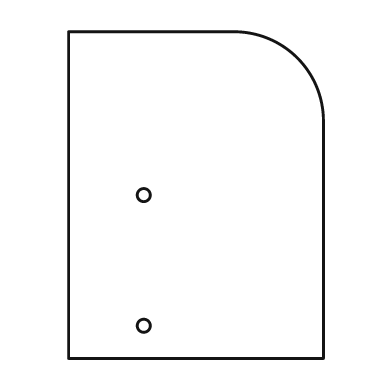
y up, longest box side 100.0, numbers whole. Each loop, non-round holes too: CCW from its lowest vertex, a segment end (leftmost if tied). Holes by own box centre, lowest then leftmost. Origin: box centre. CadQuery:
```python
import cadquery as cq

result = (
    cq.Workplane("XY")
    .moveTo(-39.0, -50.0)
    .lineTo(39.0, -50.0)
    .lineTo(39.0, 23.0)
    .threePointArc((31.0, 42.0), (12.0, 50.0))
    .lineTo(-39.0, 50.0)
    .close()
    .moveTo(-16.0, -40.0)
    .circle(2.0)
    .moveTo(-16.0, 0.0)
    .circle(2.0)
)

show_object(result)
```